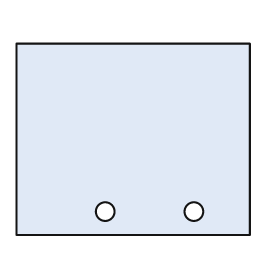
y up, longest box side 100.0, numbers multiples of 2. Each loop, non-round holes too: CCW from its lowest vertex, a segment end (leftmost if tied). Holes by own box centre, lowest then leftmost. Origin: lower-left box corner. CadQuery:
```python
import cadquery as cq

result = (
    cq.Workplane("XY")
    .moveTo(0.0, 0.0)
    .lineTo(100.0, 0.0)
    .lineTo(100.0, 82.0)
    .lineTo(0.0, 82.0)
    .close()
    .moveTo(38.0, 10.0)
    .circle(4.0)
    .moveTo(76.0, 10.0)
    .circle(4.0)
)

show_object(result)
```